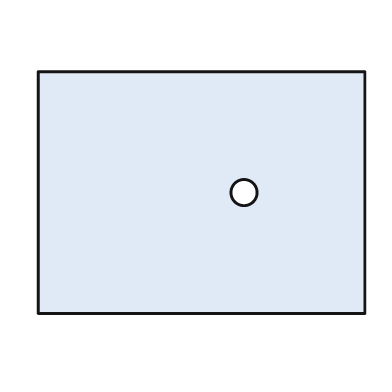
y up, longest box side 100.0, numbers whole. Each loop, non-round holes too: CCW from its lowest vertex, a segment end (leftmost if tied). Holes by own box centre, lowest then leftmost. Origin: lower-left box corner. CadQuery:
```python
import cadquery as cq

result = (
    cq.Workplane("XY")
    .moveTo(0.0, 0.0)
    .lineTo(100.0, 0.0)
    .lineTo(100.0, 74.0)
    .lineTo(0.0, 74.0)
    .close()
    .moveTo(63.0, 37.0)
    .circle(4.0)
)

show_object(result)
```